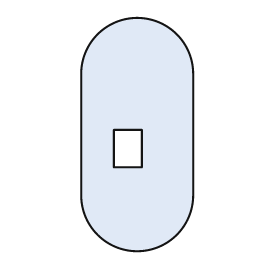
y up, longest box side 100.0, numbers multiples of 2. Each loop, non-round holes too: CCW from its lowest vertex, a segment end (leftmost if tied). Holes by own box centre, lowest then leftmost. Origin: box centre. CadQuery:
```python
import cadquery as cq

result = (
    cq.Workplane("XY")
    .moveTo(-24.0, -26.0)
    .threePointArc((0.0, -50.0), (24.0, -26.0))
    .lineTo(24.0, 26.0)
    .threePointArc((0.0, 50.0), (-24.0, 26.0))
    .close()
    .moveTo(-10.0, -14.0)
    .lineTo(2.0, -14.0)
    .lineTo(2.0, 2.0)
    .lineTo(-10.0, 2.0)
    .close()
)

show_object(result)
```